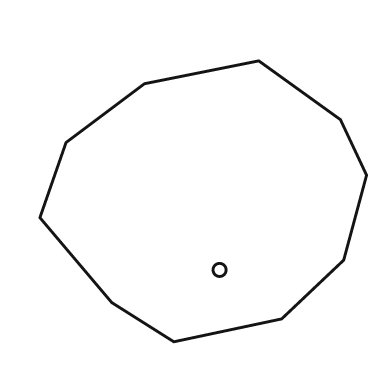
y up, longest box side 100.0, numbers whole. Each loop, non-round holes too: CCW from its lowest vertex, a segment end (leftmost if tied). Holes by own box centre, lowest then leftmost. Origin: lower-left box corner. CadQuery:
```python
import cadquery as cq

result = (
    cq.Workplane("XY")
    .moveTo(41.0, 0.0)
    .lineTo(74.0, 7.0)
    .lineTo(93.0, 25.0)
    .lineTo(100.0, 51.0)
    .lineTo(92.0, 68.0)
    .lineTo(67.0, 86.0)
    .lineTo(32.0, 79.0)
    .lineTo(8.0, 61.0)
    .lineTo(0.0, 38.0)
    .lineTo(22.0, 12.0)
    .close()
    .moveTo(55.0, 22.0)
    .circle(2.0)
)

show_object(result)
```